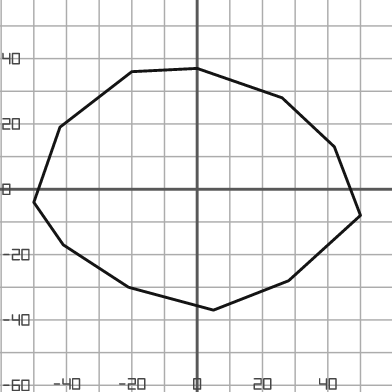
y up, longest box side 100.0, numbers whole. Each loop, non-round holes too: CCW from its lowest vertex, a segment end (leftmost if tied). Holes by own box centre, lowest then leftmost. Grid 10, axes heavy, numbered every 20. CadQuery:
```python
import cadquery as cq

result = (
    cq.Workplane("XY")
    .moveTo(5.0, -37.0)
    .lineTo(28.0, -28.0)
    .lineTo(50.0, -8.0)
    .lineTo(42.0, 13.0)
    .lineTo(26.0, 28.0)
    .lineTo(0.0, 37.0)
    .lineTo(-20.0, 36.0)
    .lineTo(-42.0, 19.0)
    .lineTo(-50.0, -4.0)
    .lineTo(-41.0, -17.0)
    .lineTo(-21.0, -30.0)
    .close()
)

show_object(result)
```